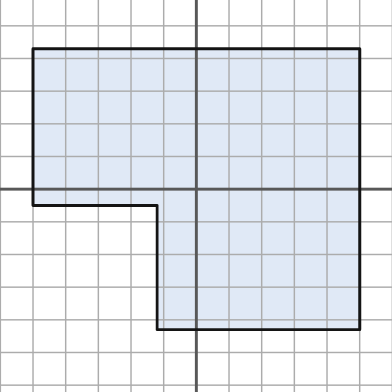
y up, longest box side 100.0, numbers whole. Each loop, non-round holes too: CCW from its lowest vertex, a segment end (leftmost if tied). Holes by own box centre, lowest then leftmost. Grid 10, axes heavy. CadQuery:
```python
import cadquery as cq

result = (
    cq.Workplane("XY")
    .moveTo(-12.0, -43.0)
    .lineTo(50.0, -43.0)
    .lineTo(50.0, 43.0)
    .lineTo(-50.0, 43.0)
    .lineTo(-50.0, -5.0)
    .lineTo(-12.0, -5.0)
    .close()
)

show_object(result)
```